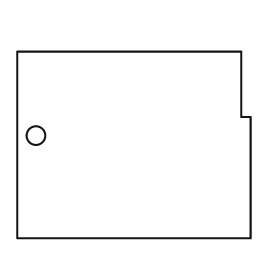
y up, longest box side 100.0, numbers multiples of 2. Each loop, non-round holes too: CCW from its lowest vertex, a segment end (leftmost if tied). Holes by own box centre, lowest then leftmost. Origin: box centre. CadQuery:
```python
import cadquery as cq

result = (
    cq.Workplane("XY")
    .moveTo(-50.0, -40.0)
    .lineTo(50.0, -40.0)
    .lineTo(50.0, 12.0)
    .lineTo(46.0, 12.0)
    .lineTo(46.0, 40.0)
    .lineTo(-50.0, 40.0)
    .close()
    .moveTo(-42.0, 4.0)
    .circle(4.0)
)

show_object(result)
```